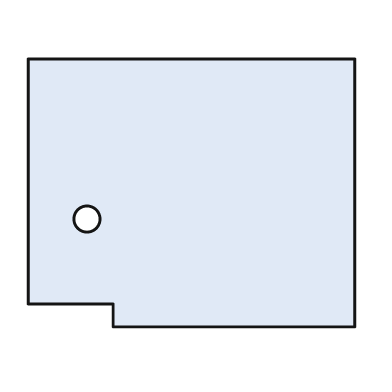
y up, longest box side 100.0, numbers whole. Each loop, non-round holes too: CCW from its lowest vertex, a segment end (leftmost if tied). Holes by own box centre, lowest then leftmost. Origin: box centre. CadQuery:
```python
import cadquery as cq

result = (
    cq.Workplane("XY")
    .moveTo(-24.0, -41.0)
    .lineTo(50.0, -41.0)
    .lineTo(50.0, 41.0)
    .lineTo(-50.0, 41.0)
    .lineTo(-50.0, -34.0)
    .lineTo(-24.0, -34.0)
    .close()
    .moveTo(-32.0, -8.0)
    .circle(4.0)
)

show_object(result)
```